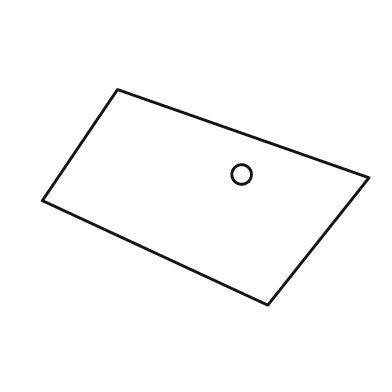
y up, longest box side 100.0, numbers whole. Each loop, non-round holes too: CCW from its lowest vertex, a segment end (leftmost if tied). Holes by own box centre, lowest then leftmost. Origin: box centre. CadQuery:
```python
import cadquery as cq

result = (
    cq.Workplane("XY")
    .moveTo(19.0, -33.0)
    .lineTo(50.0, 6.0)
    .lineTo(-27.0, 33.0)
    .lineTo(-50.0, -1.0)
    .close()
    .moveTo(11.0, 7.0)
    .circle(3.0)
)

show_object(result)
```